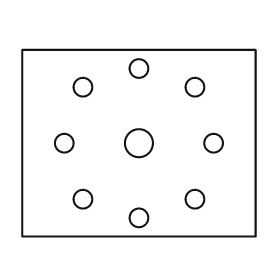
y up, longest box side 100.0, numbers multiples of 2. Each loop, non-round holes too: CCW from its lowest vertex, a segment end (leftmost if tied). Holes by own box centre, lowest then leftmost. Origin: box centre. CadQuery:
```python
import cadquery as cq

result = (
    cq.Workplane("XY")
    .moveTo(-50.0, -40.0)
    .lineTo(50.0, -40.0)
    .lineTo(50.0, 40.0)
    .lineTo(-50.0, 40.0)
    .close()
    .moveTo(0.0, -32.0)
    .circle(4.0)
    .moveTo(-24.0, -24.0)
    .circle(4.0)
    .moveTo(24.0, -24.0)
    .circle(4.0)
    .moveTo(-32.0, 0.0)
    .circle(4.0)
    .moveTo(0.0, 0.0)
    .circle(6.0)
    .moveTo(32.0, 0.0)
    .circle(4.0)
    .moveTo(-24.0, 24.0)
    .circle(4.0)
    .moveTo(24.0, 24.0)
    .circle(4.0)
    .moveTo(0.0, 32.0)
    .circle(4.0)
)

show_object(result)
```